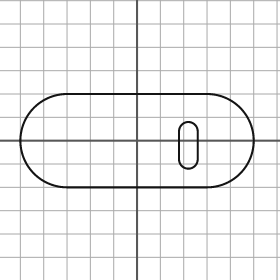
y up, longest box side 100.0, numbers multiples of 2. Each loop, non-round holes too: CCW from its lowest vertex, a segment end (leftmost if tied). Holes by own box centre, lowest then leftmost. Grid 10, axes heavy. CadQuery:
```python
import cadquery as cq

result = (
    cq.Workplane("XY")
    .moveTo(-30.0, -20.0)
    .lineTo(30.0, -20.0)
    .threePointArc((50.0, 0.0), (30.0, 20.0))
    .lineTo(-30.0, 20.0)
    .threePointArc((-50.0, 0.0), (-30.0, -20.0))
    .close()
    .moveTo(18.0, -8.0)
    .threePointArc((22.0, -12.0), (26.0, -8.0))
    .lineTo(26.0, 4.0)
    .threePointArc((22.0, 8.0), (18.0, 4.0))
    .close()
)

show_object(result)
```